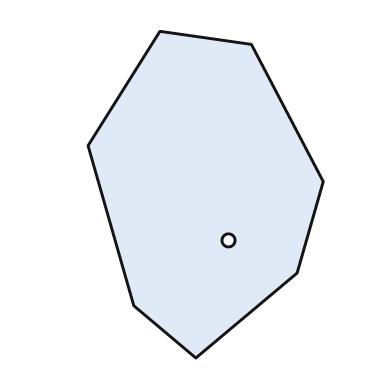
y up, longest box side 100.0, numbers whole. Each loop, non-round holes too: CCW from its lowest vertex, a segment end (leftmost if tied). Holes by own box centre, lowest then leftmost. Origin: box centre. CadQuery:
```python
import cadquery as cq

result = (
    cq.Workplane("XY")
    .moveTo(-3.0, -50.0)
    .lineTo(28.0, -24.0)
    .lineTo(36.0, 4.0)
    .lineTo(14.0, 46.0)
    .lineTo(-14.0, 50.0)
    .lineTo(-36.0, 15.0)
    .lineTo(-22.0, -34.0)
    .close()
    .moveTo(7.0, -14.0)
    .circle(2.0)
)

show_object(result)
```